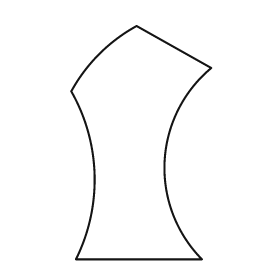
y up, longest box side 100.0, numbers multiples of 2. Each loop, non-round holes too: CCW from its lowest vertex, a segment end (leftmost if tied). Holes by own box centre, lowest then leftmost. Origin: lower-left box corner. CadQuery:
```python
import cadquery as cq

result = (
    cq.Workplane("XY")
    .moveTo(2.0, 0.0)
    .lineTo(56.0, 0.0)
    .threePointArc((40.0, 42.0), (60.0, 82.0))
    .lineTo(28.0, 100.0)
    .threePointArc((12.0, 88.0), (0.0, 72.0))
    .threePointArc((10.0, 36.0), (2.0, 0.0))
    .close()
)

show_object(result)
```